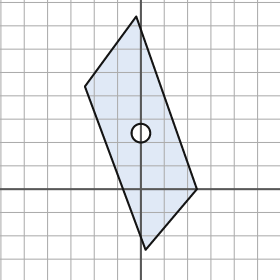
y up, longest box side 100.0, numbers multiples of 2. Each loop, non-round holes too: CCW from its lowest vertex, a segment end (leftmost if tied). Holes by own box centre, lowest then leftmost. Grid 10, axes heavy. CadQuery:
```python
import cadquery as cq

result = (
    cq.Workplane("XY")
    .moveTo(2.0, -26.0)
    .lineTo(24.0, 0.0)
    .lineTo(-2.0, 74.0)
    .lineTo(-24.0, 44.0)
    .close()
    .moveTo(0.0, 24.0)
    .circle(4.0)
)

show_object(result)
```